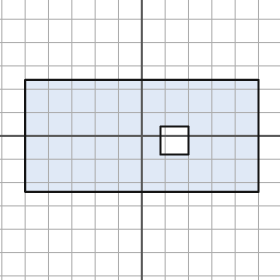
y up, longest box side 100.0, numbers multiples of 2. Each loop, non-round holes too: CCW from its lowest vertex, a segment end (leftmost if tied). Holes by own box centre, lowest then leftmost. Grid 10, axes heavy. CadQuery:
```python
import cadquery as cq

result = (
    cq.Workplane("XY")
    .moveTo(-50.0, -24.0)
    .lineTo(50.0, -24.0)
    .lineTo(50.0, 24.0)
    .lineTo(-50.0, 24.0)
    .close()
    .moveTo(8.0, -8.0)
    .lineTo(20.0, -8.0)
    .lineTo(20.0, 4.0)
    .lineTo(8.0, 4.0)
    .close()
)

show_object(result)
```